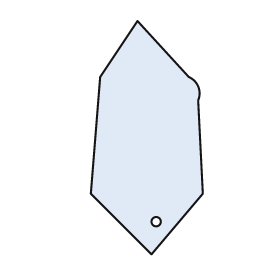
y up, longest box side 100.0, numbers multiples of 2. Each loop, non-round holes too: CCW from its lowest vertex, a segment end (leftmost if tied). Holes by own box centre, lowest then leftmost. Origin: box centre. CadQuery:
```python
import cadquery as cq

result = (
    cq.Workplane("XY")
    .moveTo(2.0, -50.0)
    .lineTo(24.0, -24.0)
    .lineTo(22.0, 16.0)
    .threePointArc((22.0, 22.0), (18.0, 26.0))
    .lineTo(-4.0, 50.0)
    .lineTo(-20.0, 26.0)
    .lineTo(-24.0, -24.0)
    .close()
    .moveTo(4.0, -36.0)
    .circle(2.0)
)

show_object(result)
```